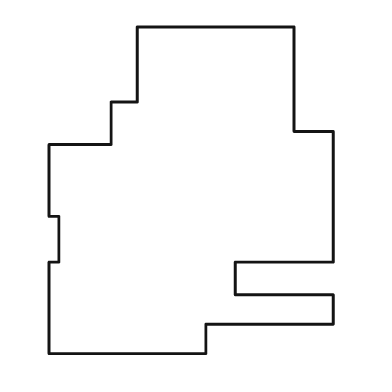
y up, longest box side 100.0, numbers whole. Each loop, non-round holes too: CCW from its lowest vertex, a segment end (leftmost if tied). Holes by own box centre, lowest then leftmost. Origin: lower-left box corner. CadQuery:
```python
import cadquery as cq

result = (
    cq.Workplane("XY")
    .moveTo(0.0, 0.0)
    .lineTo(48.0, 0.0)
    .lineTo(48.0, 9.0)
    .lineTo(87.0, 9.0)
    .lineTo(87.0, 18.0)
    .lineTo(57.0, 18.0)
    .lineTo(57.0, 28.0)
    .lineTo(87.0, 28.0)
    .lineTo(87.0, 68.0)
    .lineTo(75.0, 68.0)
    .lineTo(75.0, 100.0)
    .lineTo(27.0, 100.0)
    .lineTo(27.0, 77.0)
    .lineTo(19.0, 77.0)
    .lineTo(19.0, 64.0)
    .lineTo(0.0, 64.0)
    .lineTo(0.0, 42.0)
    .lineTo(3.0, 42.0)
    .lineTo(3.0, 28.0)
    .lineTo(0.0, 28.0)
    .close()
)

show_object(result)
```